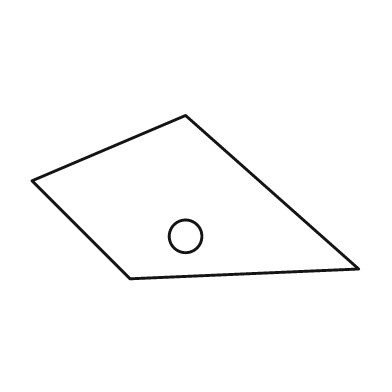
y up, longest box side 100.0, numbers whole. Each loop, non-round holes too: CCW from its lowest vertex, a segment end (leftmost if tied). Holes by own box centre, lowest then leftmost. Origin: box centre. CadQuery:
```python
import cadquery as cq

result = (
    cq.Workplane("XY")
    .moveTo(-20.0, -25.0)
    .lineTo(50.0, -22.0)
    .lineTo(-3.0, 25.0)
    .lineTo(-50.0, 5.0)
    .close()
    .moveTo(-3.0, -12.0)
    .circle(5.0)
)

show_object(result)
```